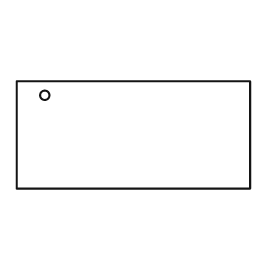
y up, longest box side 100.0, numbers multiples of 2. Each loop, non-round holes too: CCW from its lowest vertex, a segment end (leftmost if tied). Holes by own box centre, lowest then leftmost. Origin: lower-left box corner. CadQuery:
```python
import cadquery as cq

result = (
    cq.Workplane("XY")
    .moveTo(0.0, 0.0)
    .lineTo(100.0, 0.0)
    .lineTo(100.0, 46.0)
    .lineTo(0.0, 46.0)
    .close()
    .moveTo(12.0, 40.0)
    .circle(2.0)
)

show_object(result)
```